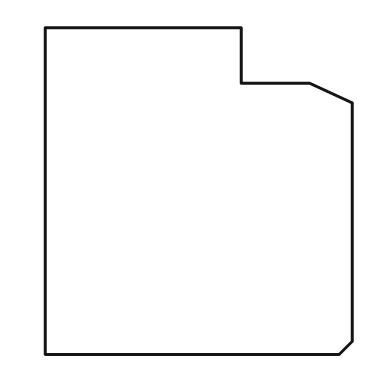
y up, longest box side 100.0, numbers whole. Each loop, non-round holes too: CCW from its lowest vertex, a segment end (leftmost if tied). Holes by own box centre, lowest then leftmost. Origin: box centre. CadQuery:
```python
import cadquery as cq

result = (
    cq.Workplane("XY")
    .moveTo(-47.0, -50.0)
    .lineTo(43.0, -50.0)
    .lineTo(47.0, -46.0)
    .lineTo(47.0, 27.0)
    .lineTo(34.0, 33.0)
    .lineTo(13.0, 33.0)
    .lineTo(13.0, 50.0)
    .lineTo(-47.0, 50.0)
    .close()
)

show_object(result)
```